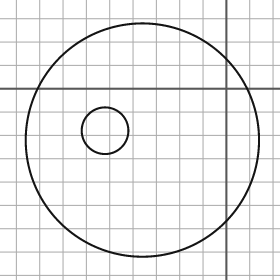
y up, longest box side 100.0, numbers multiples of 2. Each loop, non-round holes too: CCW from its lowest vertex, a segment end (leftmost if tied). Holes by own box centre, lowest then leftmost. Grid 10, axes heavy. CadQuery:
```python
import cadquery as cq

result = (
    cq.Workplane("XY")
    .moveTo(-36.0, -22.0)
    .circle(50.0)
    .moveTo(-52.0, -18.0)
    .circle(10.0)
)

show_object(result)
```